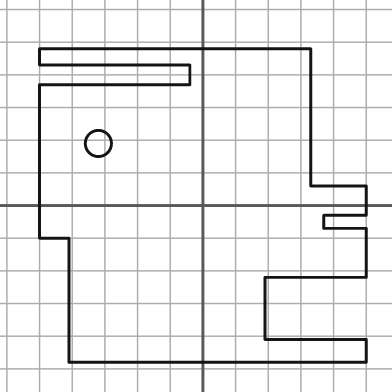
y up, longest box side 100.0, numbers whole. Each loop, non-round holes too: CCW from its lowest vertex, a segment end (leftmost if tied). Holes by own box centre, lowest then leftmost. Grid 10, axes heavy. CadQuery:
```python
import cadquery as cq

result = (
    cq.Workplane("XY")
    .moveTo(-41.0, -48.0)
    .lineTo(50.0, -48.0)
    .lineTo(50.0, -41.0)
    .lineTo(19.0, -41.0)
    .lineTo(19.0, -22.0)
    .lineTo(50.0, -22.0)
    .lineTo(50.0, -7.0)
    .lineTo(37.0, -7.0)
    .lineTo(37.0, -3.0)
    .lineTo(50.0, -3.0)
    .lineTo(50.0, 6.0)
    .lineTo(33.0, 6.0)
    .lineTo(33.0, 48.0)
    .lineTo(-50.0, 48.0)
    .lineTo(-50.0, 43.0)
    .lineTo(-4.0, 43.0)
    .lineTo(-4.0, 37.0)
    .lineTo(-50.0, 37.0)
    .lineTo(-50.0, -10.0)
    .lineTo(-41.0, -10.0)
    .close()
    .moveTo(-32.0, 19.0)
    .circle(4.0)
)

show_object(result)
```